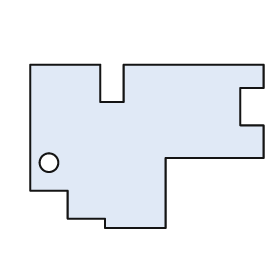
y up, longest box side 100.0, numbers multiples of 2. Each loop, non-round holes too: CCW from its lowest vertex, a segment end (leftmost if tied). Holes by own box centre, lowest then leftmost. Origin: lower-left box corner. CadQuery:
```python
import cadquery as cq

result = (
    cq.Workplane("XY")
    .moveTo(32.0, 0.0)
    .lineTo(58.0, 0.0)
    .lineTo(58.0, 30.0)
    .lineTo(100.0, 30.0)
    .lineTo(100.0, 44.0)
    .lineTo(90.0, 44.0)
    .lineTo(90.0, 60.0)
    .lineTo(100.0, 60.0)
    .lineTo(100.0, 70.0)
    .lineTo(40.0, 70.0)
    .lineTo(40.0, 54.0)
    .lineTo(30.0, 54.0)
    .lineTo(30.0, 70.0)
    .lineTo(0.0, 70.0)
    .lineTo(0.0, 16.0)
    .lineTo(16.0, 16.0)
    .lineTo(16.0, 4.0)
    .lineTo(32.0, 4.0)
    .close()
    .moveTo(8.0, 28.0)
    .circle(4.0)
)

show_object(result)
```